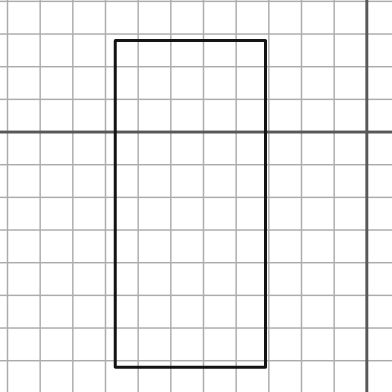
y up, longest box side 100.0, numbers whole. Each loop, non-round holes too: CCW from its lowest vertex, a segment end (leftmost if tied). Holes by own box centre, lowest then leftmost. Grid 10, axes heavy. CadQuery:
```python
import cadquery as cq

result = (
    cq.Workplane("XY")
    .moveTo(-77.0, -72.0)
    .lineTo(-31.0, -72.0)
    .lineTo(-31.0, 28.0)
    .lineTo(-77.0, 28.0)
    .close()
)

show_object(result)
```